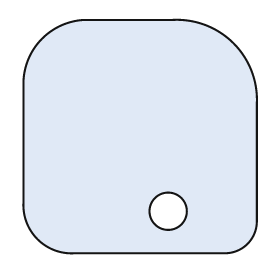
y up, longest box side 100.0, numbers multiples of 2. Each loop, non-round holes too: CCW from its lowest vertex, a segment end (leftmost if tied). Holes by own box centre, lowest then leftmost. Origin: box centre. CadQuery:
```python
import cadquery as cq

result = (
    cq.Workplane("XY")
    .moveTo(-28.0, -50.0)
    .lineTo(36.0, -50.0)
    .threePointArc((46.0, -46.0), (50.0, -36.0))
    .lineTo(50.0, 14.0)
    .threePointArc((40.0, 40.0), (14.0, 50.0))
    .lineTo(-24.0, 50.0)
    .threePointArc((-42.0, 42.0), (-50.0, 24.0))
    .lineTo(-50.0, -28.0)
    .threePointArc((-44.0, -44.0), (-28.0, -50.0))
    .close()
    .moveTo(12.0, -32.0)
    .circle(8.0)
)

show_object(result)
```